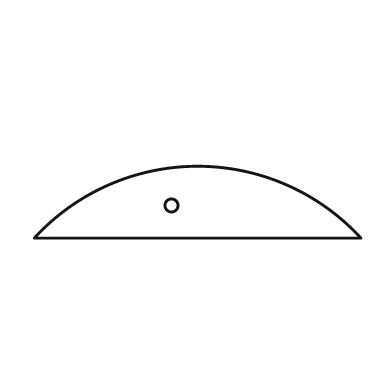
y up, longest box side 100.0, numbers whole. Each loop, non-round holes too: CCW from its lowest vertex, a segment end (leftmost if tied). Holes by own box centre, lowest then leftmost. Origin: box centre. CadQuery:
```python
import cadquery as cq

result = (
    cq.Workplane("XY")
    .moveTo(-50.0, -11.0)
    .lineTo(50.0, -11.0)
    .threePointArc((0.0, 11.0), (-50.0, -11.0))
    .close()
    .moveTo(-8.0, -1.0)
    .circle(2.0)
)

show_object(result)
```